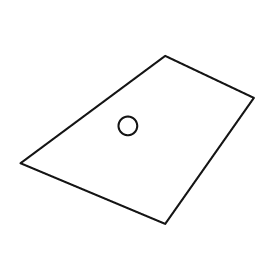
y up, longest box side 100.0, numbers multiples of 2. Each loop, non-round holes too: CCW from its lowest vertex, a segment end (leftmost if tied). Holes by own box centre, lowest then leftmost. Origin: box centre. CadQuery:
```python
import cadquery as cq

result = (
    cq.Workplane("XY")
    .moveTo(12.0, -36.0)
    .lineTo(50.0, 18.0)
    .lineTo(12.0, 36.0)
    .lineTo(-50.0, -10.0)
    .close()
    .moveTo(-4.0, 6.0)
    .circle(4.0)
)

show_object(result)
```